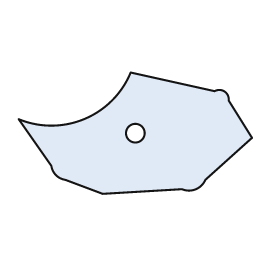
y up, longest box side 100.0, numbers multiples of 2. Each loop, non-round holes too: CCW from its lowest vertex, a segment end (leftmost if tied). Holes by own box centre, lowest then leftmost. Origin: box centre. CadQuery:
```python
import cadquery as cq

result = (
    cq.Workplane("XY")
    .moveTo(-14.0, -26.0)
    .lineTo(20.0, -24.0)
    .threePointArc((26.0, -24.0), (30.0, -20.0))
    .lineTo(50.0, -2.0)
    .lineTo(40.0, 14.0)
    .threePointArc((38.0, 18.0), (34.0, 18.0))
    .lineTo(-2.0, 26.0)
    .threePointArc((-22.0, 6.0), (-50.0, 6.0))
    .lineTo(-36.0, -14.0)
    .threePointArc((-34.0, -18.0), (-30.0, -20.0))
    .close()
    .moveTo(0.0, 0.0)
    .circle(4.0)
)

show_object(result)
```